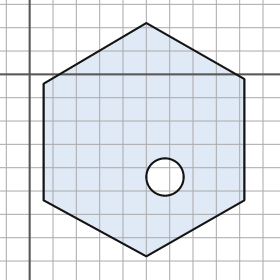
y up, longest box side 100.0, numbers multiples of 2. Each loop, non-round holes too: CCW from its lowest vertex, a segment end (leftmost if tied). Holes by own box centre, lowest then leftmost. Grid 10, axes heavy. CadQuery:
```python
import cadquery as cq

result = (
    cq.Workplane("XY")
    .moveTo(50.0, -78.0)
    .lineTo(92.0, -54.0)
    .lineTo(92.0, -2.0)
    .lineTo(50.0, 22.0)
    .lineTo(6.0, -4.0)
    .lineTo(6.0, -54.0)
    .close()
    .moveTo(58.0, -44.0)
    .circle(8.0)
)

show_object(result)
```